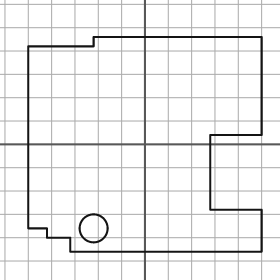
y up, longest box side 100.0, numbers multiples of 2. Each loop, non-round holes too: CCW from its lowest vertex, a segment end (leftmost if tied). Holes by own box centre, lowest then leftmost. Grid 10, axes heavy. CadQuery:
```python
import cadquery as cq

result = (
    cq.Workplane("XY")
    .moveTo(-32.0, -46.0)
    .lineTo(50.0, -46.0)
    .lineTo(50.0, -28.0)
    .lineTo(28.0, -28.0)
    .lineTo(28.0, 4.0)
    .lineTo(50.0, 4.0)
    .lineTo(50.0, 46.0)
    .lineTo(-22.0, 46.0)
    .lineTo(-22.0, 42.0)
    .lineTo(-50.0, 42.0)
    .lineTo(-50.0, -36.0)
    .lineTo(-42.0, -36.0)
    .lineTo(-42.0, -40.0)
    .lineTo(-32.0, -40.0)
    .close()
    .moveTo(-22.0, -36.0)
    .circle(6.0)
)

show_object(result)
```